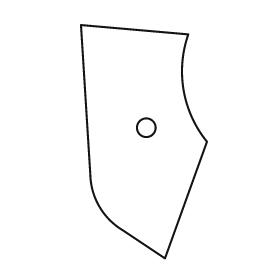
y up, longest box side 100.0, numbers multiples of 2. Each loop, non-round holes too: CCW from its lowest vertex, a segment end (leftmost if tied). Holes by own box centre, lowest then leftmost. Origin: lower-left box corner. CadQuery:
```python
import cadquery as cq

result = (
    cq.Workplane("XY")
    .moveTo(36.0, 0.0)
    .lineTo(54.0, 50.0)
    .threePointArc((44.0, 72.0), (46.0, 96.0))
    .lineTo(0.0, 100.0)
    .lineTo(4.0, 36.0)
    .threePointArc((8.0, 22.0), (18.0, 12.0))
    .close()
    .moveTo(28.0, 56.0)
    .circle(4.0)
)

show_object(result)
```